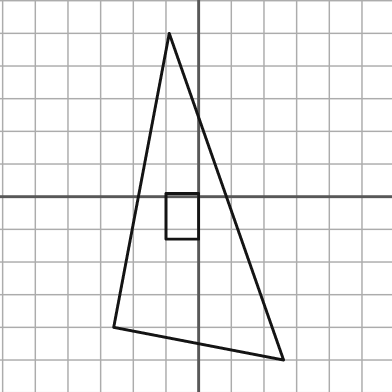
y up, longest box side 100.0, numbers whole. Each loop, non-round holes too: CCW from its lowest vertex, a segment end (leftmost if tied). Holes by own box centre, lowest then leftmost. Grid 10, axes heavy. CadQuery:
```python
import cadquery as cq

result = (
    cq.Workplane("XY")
    .moveTo(26.0, -50.0)
    .lineTo(-9.0, 50.0)
    .lineTo(-26.0, -40.0)
    .close()
    .moveTo(-10.0, -13.0)
    .lineTo(0.0, -13.0)
    .lineTo(0.0, 1.0)
    .lineTo(-10.0, 1.0)
    .close()
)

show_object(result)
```